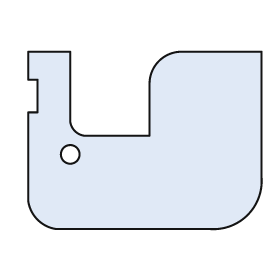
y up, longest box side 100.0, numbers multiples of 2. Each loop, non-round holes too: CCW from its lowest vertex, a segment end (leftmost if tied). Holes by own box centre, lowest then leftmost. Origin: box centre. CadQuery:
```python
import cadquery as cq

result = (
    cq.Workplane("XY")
    .moveTo(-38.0, -38.0)
    .lineTo(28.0, -38.0)
    .threePointArc((44.0, -32.0), (50.0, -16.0))
    .lineTo(50.0, 38.0)
    .lineTo(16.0, 38.0)
    .threePointArc((6.0, 34.0), (2.0, 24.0))
    .lineTo(2.0, 2.0)
    .lineTo(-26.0, 2.0)
    .threePointArc((-30.0, 4.0), (-32.0, 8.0))
    .lineTo(-32.0, 38.0)
    .lineTo(-50.0, 38.0)
    .lineTo(-50.0, 26.0)
    .lineTo(-46.0, 26.0)
    .lineTo(-46.0, 12.0)
    .lineTo(-50.0, 12.0)
    .lineTo(-50.0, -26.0)
    .threePointArc((-46.0, -34.0), (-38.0, -38.0))
    .close()
    .moveTo(-32.0, -6.0)
    .circle(4.0)
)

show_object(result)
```